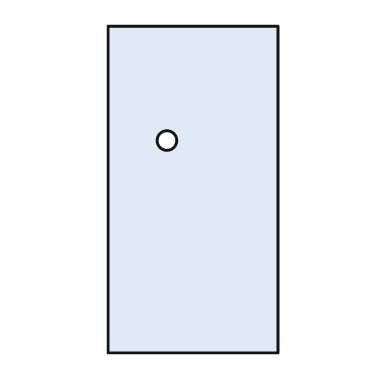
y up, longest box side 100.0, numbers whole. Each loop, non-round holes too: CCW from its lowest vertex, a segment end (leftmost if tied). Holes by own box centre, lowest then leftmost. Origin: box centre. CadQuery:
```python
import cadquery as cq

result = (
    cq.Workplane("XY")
    .moveTo(-26.0, -50.0)
    .lineTo(26.0, -50.0)
    .lineTo(26.0, 50.0)
    .lineTo(-26.0, 50.0)
    .close()
    .moveTo(-8.0, 15.0)
    .circle(3.0)
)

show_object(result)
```